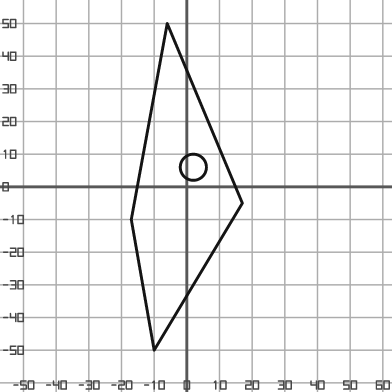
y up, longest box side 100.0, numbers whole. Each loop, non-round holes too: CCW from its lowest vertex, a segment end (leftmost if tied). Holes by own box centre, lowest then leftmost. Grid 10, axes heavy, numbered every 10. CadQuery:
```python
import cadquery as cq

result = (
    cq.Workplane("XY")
    .moveTo(-10.0, -50.0)
    .lineTo(17.0, -5.0)
    .lineTo(-6.0, 50.0)
    .lineTo(-17.0, -10.0)
    .close()
    .moveTo(2.0, 6.0)
    .circle(4.0)
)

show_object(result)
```